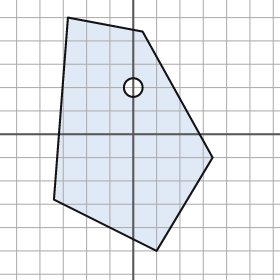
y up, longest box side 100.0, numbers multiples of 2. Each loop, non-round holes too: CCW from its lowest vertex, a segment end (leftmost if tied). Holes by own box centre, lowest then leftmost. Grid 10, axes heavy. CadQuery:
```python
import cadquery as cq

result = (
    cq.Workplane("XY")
    .moveTo(10.0, -50.0)
    .lineTo(34.0, -10.0)
    .lineTo(4.0, 44.0)
    .lineTo(-28.0, 50.0)
    .lineTo(-34.0, -28.0)
    .close()
    .moveTo(0.0, 20.0)
    .circle(4.0)
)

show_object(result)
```